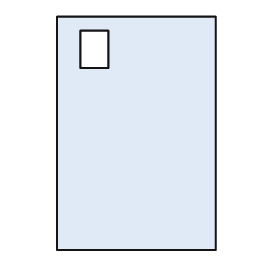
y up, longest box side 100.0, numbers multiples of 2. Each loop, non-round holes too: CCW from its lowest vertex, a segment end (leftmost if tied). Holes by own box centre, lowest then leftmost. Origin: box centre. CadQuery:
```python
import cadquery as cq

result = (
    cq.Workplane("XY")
    .moveTo(-34.0, -50.0)
    .lineTo(34.0, -50.0)
    .lineTo(34.0, 50.0)
    .lineTo(-34.0, 50.0)
    .close()
    .moveTo(-24.0, 28.0)
    .lineTo(-12.0, 28.0)
    .lineTo(-12.0, 44.0)
    .lineTo(-24.0, 44.0)
    .close()
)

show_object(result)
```